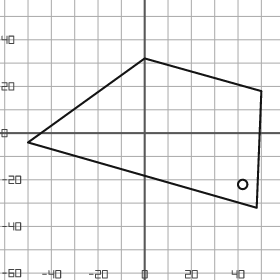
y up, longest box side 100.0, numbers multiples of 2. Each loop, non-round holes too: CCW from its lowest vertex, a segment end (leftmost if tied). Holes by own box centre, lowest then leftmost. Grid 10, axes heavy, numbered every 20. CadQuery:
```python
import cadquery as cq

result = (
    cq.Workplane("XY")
    .moveTo(48.0, -32.0)
    .lineTo(50.0, 18.0)
    .lineTo(0.0, 32.0)
    .lineTo(-50.0, -4.0)
    .close()
    .moveTo(42.0, -22.0)
    .circle(2.0)
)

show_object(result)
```